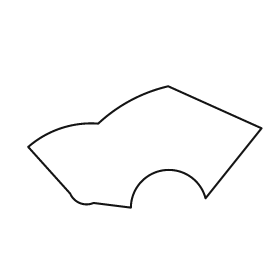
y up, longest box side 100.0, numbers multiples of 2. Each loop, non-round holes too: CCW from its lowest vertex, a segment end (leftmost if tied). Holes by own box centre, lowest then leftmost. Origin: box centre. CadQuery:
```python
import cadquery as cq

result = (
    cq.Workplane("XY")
    .moveTo(-6.0, -26.0)
    .threePointArc((8.0, -10.0), (26.0, -22.0))
    .lineTo(50.0, 8.0)
    .lineTo(10.0, 26.0)
    .threePointArc((-6.0, 20.0), (-20.0, 10.0))
    .threePointArc((-36.0, 8.0), (-50.0, 0.0))
    .lineTo(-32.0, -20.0)
    .threePointArc((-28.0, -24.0), (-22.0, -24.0))
    .close()
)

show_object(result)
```